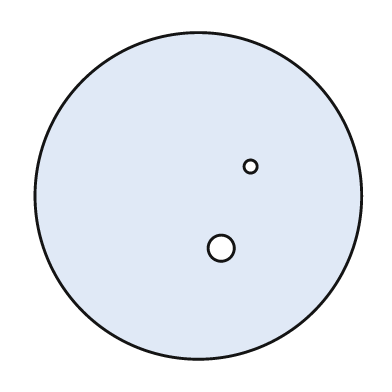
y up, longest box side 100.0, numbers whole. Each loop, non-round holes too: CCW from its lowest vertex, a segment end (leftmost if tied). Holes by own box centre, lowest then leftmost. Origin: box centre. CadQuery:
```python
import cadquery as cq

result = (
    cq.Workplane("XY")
    .moveTo(0.0, 0.0)
    .circle(50.0)
    .moveTo(7.0, -16.0)
    .circle(4.0)
    .moveTo(16.0, 9.0)
    .circle(2.0)
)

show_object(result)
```